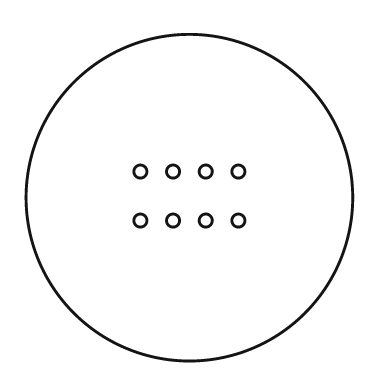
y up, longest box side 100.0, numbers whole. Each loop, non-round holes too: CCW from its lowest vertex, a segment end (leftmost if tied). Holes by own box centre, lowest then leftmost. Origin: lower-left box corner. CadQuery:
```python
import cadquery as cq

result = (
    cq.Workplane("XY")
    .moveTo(50.0, 50.0)
    .circle(50.0)
    .moveTo(35.0, 43.0)
    .circle(2.0)
    .moveTo(45.0, 43.0)
    .circle(2.0)
    .moveTo(55.0, 43.0)
    .circle(2.0)
    .moveTo(65.0, 43.0)
    .circle(2.0)
    .moveTo(35.0, 58.0)
    .circle(2.0)
    .moveTo(45.0, 58.0)
    .circle(2.0)
    .moveTo(55.0, 58.0)
    .circle(2.0)
    .moveTo(65.0, 58.0)
    .circle(2.0)
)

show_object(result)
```